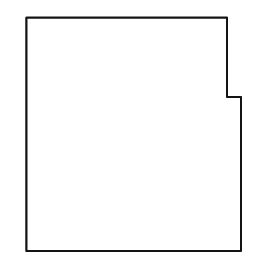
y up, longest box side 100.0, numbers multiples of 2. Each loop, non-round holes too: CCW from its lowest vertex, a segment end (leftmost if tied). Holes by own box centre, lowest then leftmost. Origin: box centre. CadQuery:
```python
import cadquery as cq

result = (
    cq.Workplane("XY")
    .moveTo(-46.0, -50.0)
    .lineTo(46.0, -50.0)
    .lineTo(46.0, 16.0)
    .lineTo(40.0, 16.0)
    .lineTo(40.0, 50.0)
    .lineTo(-46.0, 50.0)
    .close()
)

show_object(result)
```